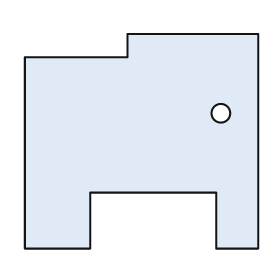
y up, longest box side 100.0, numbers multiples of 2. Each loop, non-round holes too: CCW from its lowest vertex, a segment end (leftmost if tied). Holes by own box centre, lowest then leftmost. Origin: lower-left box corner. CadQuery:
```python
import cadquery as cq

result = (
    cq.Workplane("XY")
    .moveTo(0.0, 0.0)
    .lineTo(28.0, 0.0)
    .lineTo(28.0, 24.0)
    .lineTo(82.0, 24.0)
    .lineTo(82.0, 0.0)
    .lineTo(100.0, 0.0)
    .lineTo(100.0, 92.0)
    .lineTo(44.0, 92.0)
    .lineTo(44.0, 82.0)
    .lineTo(0.0, 82.0)
    .close()
    .moveTo(84.0, 58.0)
    .circle(4.0)
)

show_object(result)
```